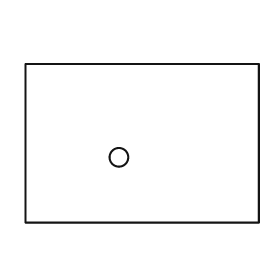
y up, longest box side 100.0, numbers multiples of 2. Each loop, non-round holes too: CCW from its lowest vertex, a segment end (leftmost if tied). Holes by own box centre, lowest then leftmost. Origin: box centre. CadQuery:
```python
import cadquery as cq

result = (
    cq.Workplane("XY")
    .moveTo(-50.0, -34.0)
    .lineTo(50.0, -34.0)
    .lineTo(50.0, 34.0)
    .lineTo(-50.0, 34.0)
    .close()
    .moveTo(-10.0, -6.0)
    .circle(4.0)
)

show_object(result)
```